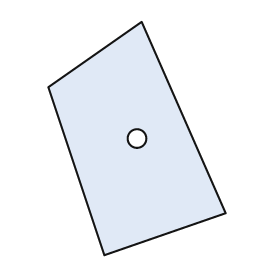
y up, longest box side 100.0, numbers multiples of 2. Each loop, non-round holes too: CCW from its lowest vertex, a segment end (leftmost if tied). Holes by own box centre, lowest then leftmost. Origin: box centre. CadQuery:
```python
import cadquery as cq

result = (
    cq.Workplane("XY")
    .moveTo(-14.0, -50.0)
    .lineTo(38.0, -32.0)
    .lineTo(2.0, 50.0)
    .lineTo(-38.0, 22.0)
    .close()
    .moveTo(0.0, 0.0)
    .circle(4.0)
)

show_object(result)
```